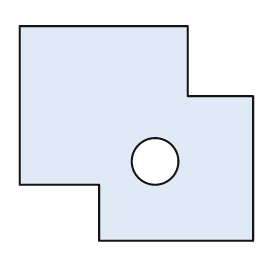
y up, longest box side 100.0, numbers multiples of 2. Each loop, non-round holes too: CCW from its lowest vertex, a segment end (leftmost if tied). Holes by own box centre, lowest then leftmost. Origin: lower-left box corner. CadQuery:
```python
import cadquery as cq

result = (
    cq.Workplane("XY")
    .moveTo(34.0, 0.0)
    .lineTo(100.0, 0.0)
    .lineTo(100.0, 62.0)
    .lineTo(72.0, 62.0)
    .lineTo(72.0, 92.0)
    .lineTo(0.0, 92.0)
    .lineTo(0.0, 24.0)
    .lineTo(34.0, 24.0)
    .close()
    .moveTo(58.0, 34.0)
    .circle(10.0)
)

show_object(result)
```